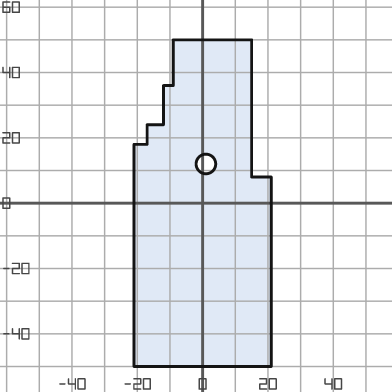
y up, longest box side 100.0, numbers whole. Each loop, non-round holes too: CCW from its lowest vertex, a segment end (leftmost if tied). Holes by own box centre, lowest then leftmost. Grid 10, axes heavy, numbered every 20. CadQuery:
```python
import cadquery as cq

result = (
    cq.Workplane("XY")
    .moveTo(-21.0, -50.0)
    .lineTo(21.0, -50.0)
    .lineTo(21.0, 8.0)
    .lineTo(15.0, 8.0)
    .lineTo(15.0, 50.0)
    .lineTo(-9.0, 50.0)
    .lineTo(-9.0, 36.0)
    .lineTo(-12.0, 36.0)
    .lineTo(-12.0, 24.0)
    .lineTo(-17.0, 24.0)
    .lineTo(-17.0, 18.0)
    .lineTo(-21.0, 18.0)
    .close()
    .moveTo(1.0, 12.0)
    .circle(3.0)
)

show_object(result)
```